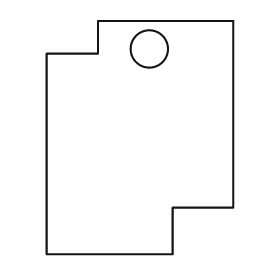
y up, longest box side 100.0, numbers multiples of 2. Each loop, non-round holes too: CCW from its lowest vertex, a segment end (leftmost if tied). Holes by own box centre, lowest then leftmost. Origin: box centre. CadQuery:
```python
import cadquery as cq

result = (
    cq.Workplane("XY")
    .moveTo(-40.0, -50.0)
    .lineTo(14.0, -50.0)
    .lineTo(14.0, -30.0)
    .lineTo(40.0, -30.0)
    .lineTo(40.0, 50.0)
    .lineTo(-18.0, 50.0)
    .lineTo(-18.0, 36.0)
    .lineTo(-40.0, 36.0)
    .close()
    .moveTo(4.0, 38.0)
    .circle(8.0)
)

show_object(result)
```